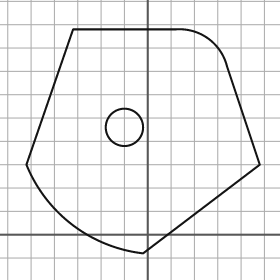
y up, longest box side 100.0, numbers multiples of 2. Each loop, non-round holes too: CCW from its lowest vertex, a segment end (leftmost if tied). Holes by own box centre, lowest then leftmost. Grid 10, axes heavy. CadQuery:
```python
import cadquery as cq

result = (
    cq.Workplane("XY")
    .moveTo(-2.0, -8.0)
    .lineTo(48.0, 30.0)
    .lineTo(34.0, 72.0)
    .threePointArc((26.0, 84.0), (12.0, 88.0))
    .lineTo(-32.0, 88.0)
    .lineTo(-52.0, 30.0)
    .threePointArc((-32.0, 4.0), (-2.0, -8.0))
    .close()
    .moveTo(-10.0, 46.0)
    .circle(8.0)
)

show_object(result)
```